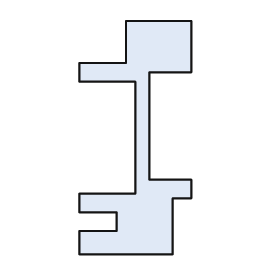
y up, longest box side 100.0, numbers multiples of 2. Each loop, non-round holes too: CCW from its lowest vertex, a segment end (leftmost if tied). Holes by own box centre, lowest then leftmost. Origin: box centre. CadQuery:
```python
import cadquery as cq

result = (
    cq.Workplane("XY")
    .moveTo(-24.0, -50.0)
    .lineTo(16.0, -50.0)
    .lineTo(16.0, -26.0)
    .lineTo(24.0, -26.0)
    .lineTo(24.0, -18.0)
    .lineTo(6.0, -18.0)
    .lineTo(6.0, 28.0)
    .lineTo(24.0, 28.0)
    .lineTo(24.0, 50.0)
    .lineTo(-4.0, 50.0)
    .lineTo(-4.0, 32.0)
    .lineTo(-24.0, 32.0)
    .lineTo(-24.0, 24.0)
    .lineTo(0.0, 24.0)
    .lineTo(0.0, -24.0)
    .lineTo(-24.0, -24.0)
    .lineTo(-24.0, -32.0)
    .lineTo(-8.0, -32.0)
    .lineTo(-8.0, -40.0)
    .lineTo(-24.0, -40.0)
    .close()
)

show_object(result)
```